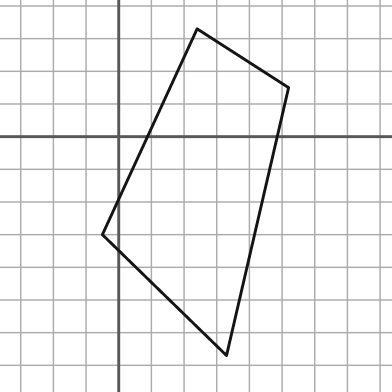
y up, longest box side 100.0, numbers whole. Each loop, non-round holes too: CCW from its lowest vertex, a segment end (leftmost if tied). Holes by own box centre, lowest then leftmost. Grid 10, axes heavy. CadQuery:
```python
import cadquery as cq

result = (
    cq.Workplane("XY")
    .moveTo(33.0, -67.0)
    .lineTo(52.0, 15.0)
    .lineTo(24.0, 33.0)
    .lineTo(-5.0, -30.0)
    .close()
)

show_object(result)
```